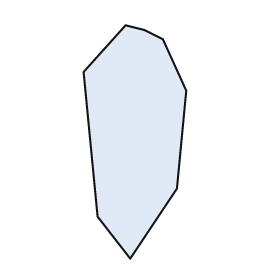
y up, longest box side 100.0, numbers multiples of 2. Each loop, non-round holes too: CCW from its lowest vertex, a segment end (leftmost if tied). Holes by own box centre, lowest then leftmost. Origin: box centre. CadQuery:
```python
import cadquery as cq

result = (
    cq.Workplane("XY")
    .moveTo(-2.0, -50.0)
    .lineTo(18.0, -20.0)
    .lineTo(22.0, 22.0)
    .lineTo(12.0, 44.0)
    .lineTo(4.0, 48.0)
    .lineTo(-4.0, 50.0)
    .lineTo(-22.0, 30.0)
    .lineTo(-16.0, -32.0)
    .close()
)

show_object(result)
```